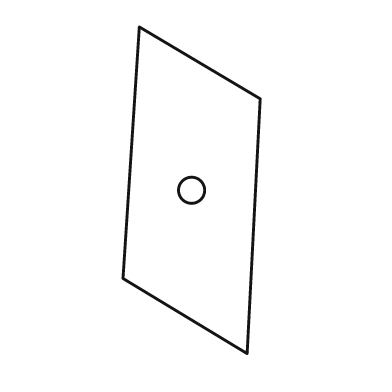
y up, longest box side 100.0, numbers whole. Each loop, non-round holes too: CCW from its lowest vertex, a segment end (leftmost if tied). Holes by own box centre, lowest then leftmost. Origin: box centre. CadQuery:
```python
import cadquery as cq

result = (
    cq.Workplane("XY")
    .moveTo(17.0, -50.0)
    .lineTo(21.0, 28.0)
    .lineTo(-16.0, 50.0)
    .lineTo(-21.0, -27.0)
    .close()
    .moveTo(0.0, 0.0)
    .circle(4.0)
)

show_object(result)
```